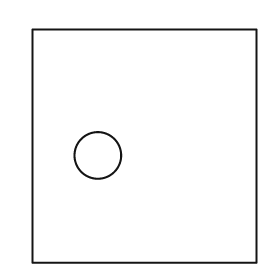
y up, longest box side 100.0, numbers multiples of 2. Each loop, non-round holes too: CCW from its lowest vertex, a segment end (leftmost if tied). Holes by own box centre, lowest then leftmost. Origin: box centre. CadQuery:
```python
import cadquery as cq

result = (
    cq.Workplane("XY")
    .moveTo(-48.0, -50.0)
    .lineTo(48.0, -50.0)
    .lineTo(48.0, 50.0)
    .lineTo(-48.0, 50.0)
    .close()
    .moveTo(-20.0, -4.0)
    .circle(10.0)
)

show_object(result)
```